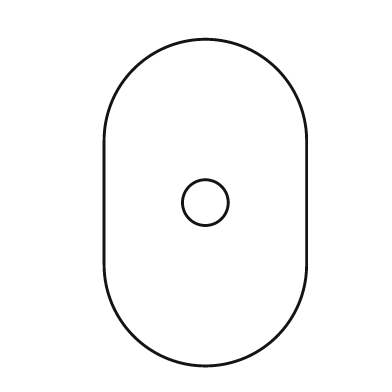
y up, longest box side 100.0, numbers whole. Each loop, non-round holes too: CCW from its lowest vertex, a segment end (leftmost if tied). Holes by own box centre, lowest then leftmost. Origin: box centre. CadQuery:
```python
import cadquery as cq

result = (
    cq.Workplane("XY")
    .moveTo(-31.0, -19.0)
    .threePointArc((0.0, -50.0), (31.0, -19.0))
    .lineTo(31.0, 19.0)
    .threePointArc((0.0, 50.0), (-31.0, 19.0))
    .close()
    .moveTo(0.0, 0.0)
    .circle(7.0)
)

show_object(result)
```